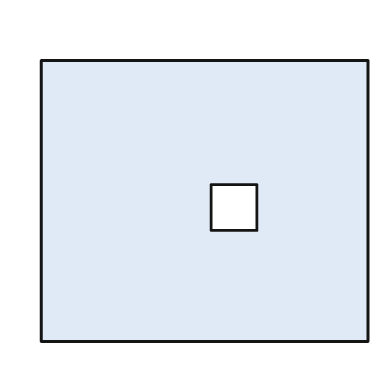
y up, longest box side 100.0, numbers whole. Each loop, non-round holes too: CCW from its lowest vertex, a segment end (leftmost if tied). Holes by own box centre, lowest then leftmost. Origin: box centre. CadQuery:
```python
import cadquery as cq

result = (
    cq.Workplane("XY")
    .moveTo(-50.0, -43.0)
    .lineTo(50.0, -43.0)
    .lineTo(50.0, 43.0)
    .lineTo(-50.0, 43.0)
    .close()
    .moveTo(2.0, -9.0)
    .lineTo(16.0, -9.0)
    .lineTo(16.0, 5.0)
    .lineTo(2.0, 5.0)
    .close()
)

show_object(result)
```